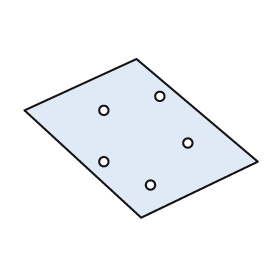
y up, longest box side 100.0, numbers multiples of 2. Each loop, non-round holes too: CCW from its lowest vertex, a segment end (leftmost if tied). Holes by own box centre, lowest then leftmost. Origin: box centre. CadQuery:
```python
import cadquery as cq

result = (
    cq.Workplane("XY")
    .moveTo(0.0, -34.0)
    .lineTo(50.0, -10.0)
    .lineTo(-2.0, 34.0)
    .lineTo(-50.0, 12.0)
    .close()
    .moveTo(4.0, -20.0)
    .circle(2.0)
    .moveTo(-16.0, -10.0)
    .circle(2.0)
    .moveTo(20.0, -2.0)
    .circle(2.0)
    .moveTo(-16.0, 12.0)
    .circle(2.0)
    .moveTo(8.0, 18.0)
    .circle(2.0)
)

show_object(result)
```